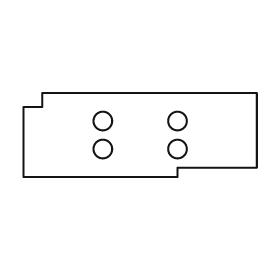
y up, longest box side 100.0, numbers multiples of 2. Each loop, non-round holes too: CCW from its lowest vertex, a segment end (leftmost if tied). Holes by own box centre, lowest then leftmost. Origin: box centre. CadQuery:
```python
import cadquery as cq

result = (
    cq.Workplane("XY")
    .moveTo(-50.0, -18.0)
    .lineTo(16.0, -18.0)
    .lineTo(16.0, -14.0)
    .lineTo(50.0, -14.0)
    .lineTo(50.0, 18.0)
    .lineTo(-42.0, 18.0)
    .lineTo(-42.0, 12.0)
    .lineTo(-50.0, 12.0)
    .close()
    .moveTo(-16.0, -6.0)
    .circle(4.0)
    .moveTo(16.0, -6.0)
    .circle(4.0)
    .moveTo(-16.0, 6.0)
    .circle(4.0)
    .moveTo(16.0, 6.0)
    .circle(4.0)
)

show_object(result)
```